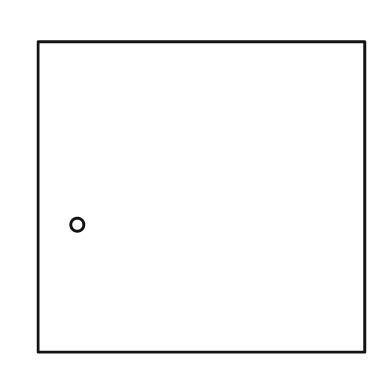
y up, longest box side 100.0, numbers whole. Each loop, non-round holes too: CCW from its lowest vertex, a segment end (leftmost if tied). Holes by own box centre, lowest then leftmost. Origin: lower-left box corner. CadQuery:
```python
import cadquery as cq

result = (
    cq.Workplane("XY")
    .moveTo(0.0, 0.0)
    .lineTo(100.0, 0.0)
    .lineTo(100.0, 95.0)
    .lineTo(0.0, 95.0)
    .close()
    .moveTo(12.0, 39.0)
    .circle(2.0)
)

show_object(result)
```